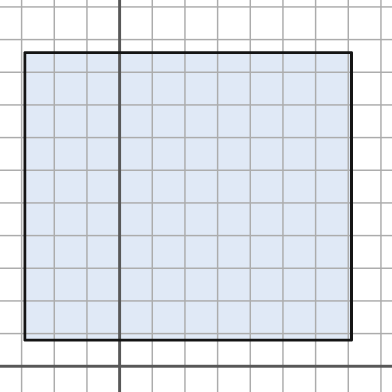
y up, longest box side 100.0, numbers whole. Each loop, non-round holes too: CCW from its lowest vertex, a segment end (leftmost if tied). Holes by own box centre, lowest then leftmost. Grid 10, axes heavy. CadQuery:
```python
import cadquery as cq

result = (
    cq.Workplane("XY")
    .moveTo(-29.0, 8.0)
    .lineTo(71.0, 8.0)
    .lineTo(71.0, 96.0)
    .lineTo(-29.0, 96.0)
    .close()
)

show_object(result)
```